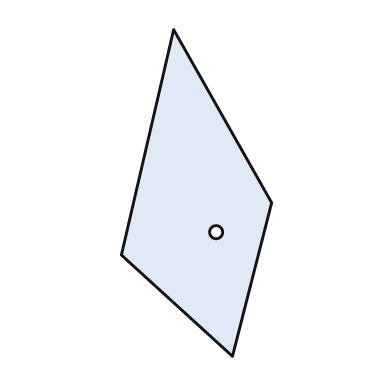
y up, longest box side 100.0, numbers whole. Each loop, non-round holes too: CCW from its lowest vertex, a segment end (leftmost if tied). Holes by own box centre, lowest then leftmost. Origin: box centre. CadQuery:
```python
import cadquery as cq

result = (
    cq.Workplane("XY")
    .moveTo(11.0, -50.0)
    .lineTo(23.0, -3.0)
    .lineTo(-7.0, 50.0)
    .lineTo(-23.0, -19.0)
    .close()
    .moveTo(6.0, -12.0)
    .circle(2.0)
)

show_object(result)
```